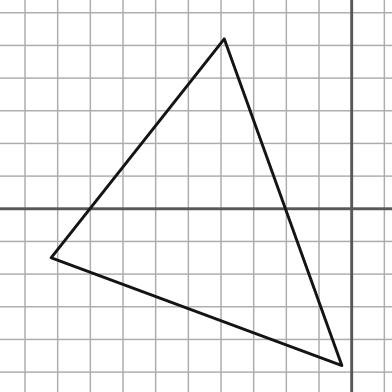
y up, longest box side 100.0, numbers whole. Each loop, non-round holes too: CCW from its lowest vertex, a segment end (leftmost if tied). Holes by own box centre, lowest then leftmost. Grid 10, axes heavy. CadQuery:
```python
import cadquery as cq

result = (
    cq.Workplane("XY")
    .moveTo(-3.0, -48.0)
    .lineTo(-39.0, 52.0)
    .lineTo(-92.0, -15.0)
    .close()
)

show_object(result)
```